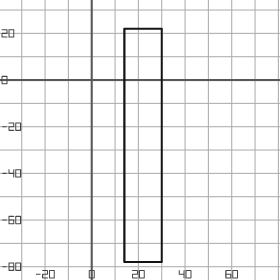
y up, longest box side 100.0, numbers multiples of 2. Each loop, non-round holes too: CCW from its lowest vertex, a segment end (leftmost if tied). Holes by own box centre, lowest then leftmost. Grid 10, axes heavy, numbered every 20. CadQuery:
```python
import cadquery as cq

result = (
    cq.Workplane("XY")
    .moveTo(14.0, -78.0)
    .lineTo(30.0, -78.0)
    .lineTo(30.0, 22.0)
    .lineTo(14.0, 22.0)
    .close()
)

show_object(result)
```